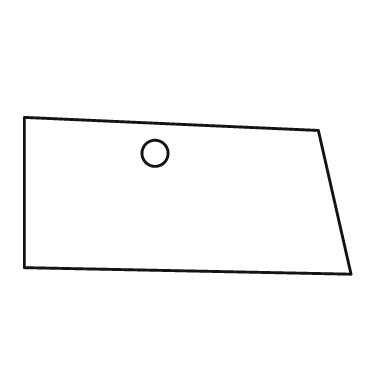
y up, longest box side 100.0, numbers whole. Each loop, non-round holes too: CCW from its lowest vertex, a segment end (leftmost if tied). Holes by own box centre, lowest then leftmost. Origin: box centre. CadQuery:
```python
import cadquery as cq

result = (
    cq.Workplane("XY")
    .moveTo(50.0, -24.0)
    .lineTo(40.0, 20.0)
    .lineTo(-50.0, 24.0)
    .lineTo(-50.0, -22.0)
    .close()
    .moveTo(-10.0, 13.0)
    .circle(4.0)
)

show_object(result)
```